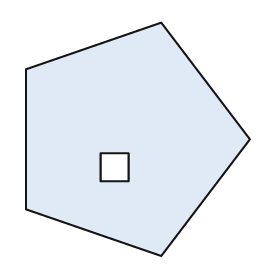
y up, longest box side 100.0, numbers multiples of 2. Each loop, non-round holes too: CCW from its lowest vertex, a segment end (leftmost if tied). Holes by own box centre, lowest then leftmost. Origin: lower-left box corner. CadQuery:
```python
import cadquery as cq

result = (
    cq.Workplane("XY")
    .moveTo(58.0, 0.0)
    .lineTo(96.0, 50.0)
    .lineTo(58.0, 100.0)
    .lineTo(0.0, 80.0)
    .lineTo(0.0, 20.0)
    .close()
    .moveTo(32.0, 32.0)
    .lineTo(44.0, 32.0)
    .lineTo(44.0, 44.0)
    .lineTo(32.0, 44.0)
    .close()
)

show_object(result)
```